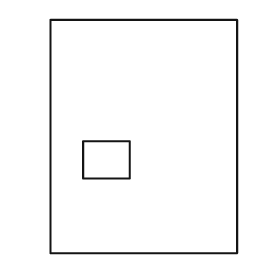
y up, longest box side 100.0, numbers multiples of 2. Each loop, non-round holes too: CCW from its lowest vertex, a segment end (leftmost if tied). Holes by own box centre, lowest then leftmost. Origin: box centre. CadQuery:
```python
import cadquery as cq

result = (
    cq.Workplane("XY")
    .moveTo(-40.0, -50.0)
    .lineTo(40.0, -50.0)
    .lineTo(40.0, 50.0)
    .lineTo(-40.0, 50.0)
    .close()
    .moveTo(-26.0, -18.0)
    .lineTo(-6.0, -18.0)
    .lineTo(-6.0, -2.0)
    .lineTo(-26.0, -2.0)
    .close()
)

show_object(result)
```